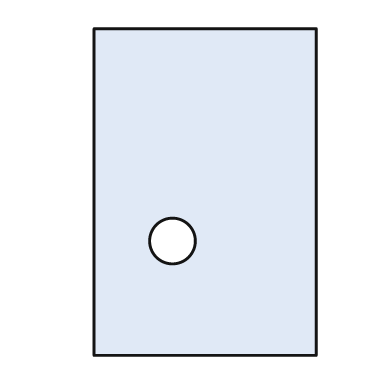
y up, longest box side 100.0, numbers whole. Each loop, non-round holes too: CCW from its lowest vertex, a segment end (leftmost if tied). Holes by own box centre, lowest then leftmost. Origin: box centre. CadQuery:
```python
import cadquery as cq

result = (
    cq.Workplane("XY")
    .moveTo(-34.0, -50.0)
    .lineTo(34.0, -50.0)
    .lineTo(34.0, 50.0)
    .lineTo(-34.0, 50.0)
    .close()
    .moveTo(-10.0, -15.0)
    .circle(7.0)
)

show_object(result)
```